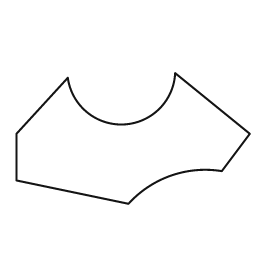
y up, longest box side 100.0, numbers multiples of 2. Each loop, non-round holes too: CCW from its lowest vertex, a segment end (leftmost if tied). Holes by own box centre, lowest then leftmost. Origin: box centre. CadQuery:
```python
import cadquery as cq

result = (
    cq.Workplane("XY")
    .moveTo(-2.0, -28.0)
    .threePointArc((16.0, -16.0), (38.0, -14.0))
    .lineTo(50.0, 2.0)
    .lineTo(18.0, 28.0)
    .threePointArc((-4.0, 6.0), (-28.0, 26.0))
    .lineTo(-50.0, 2.0)
    .lineTo(-50.0, -18.0)
    .close()
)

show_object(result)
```